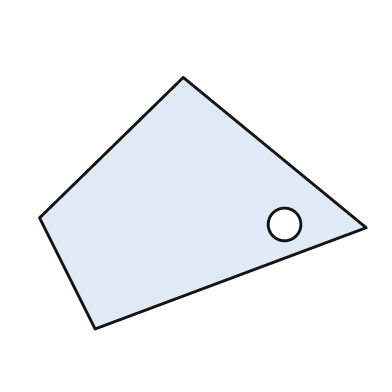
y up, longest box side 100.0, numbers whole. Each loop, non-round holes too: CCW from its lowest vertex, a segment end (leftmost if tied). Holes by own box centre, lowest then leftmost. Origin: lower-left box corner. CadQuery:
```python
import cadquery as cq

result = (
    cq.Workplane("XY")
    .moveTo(17.0, 0.0)
    .lineTo(100.0, 31.0)
    .lineTo(44.0, 77.0)
    .lineTo(0.0, 34.0)
    .close()
    .moveTo(75.0, 32.0)
    .circle(5.0)
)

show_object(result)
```